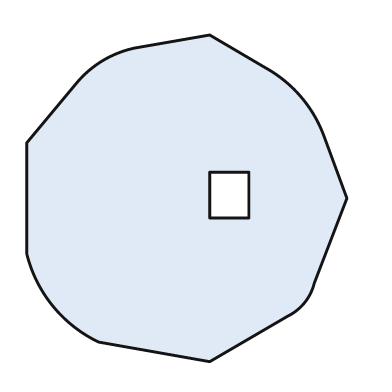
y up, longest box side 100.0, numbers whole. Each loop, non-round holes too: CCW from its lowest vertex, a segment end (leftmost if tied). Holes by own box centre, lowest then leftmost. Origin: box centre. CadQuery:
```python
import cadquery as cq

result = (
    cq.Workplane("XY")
    .moveTo(7.0, -50.0)
    .lineTo(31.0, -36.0)
    .threePointArc((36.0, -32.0), (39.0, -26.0))
    .lineTo(49.0, 0.0)
    .lineTo(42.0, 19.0)
    .threePointArc((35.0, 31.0), (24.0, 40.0))
    .lineTo(7.0, 50.0)
    .lineTo(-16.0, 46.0)
    .threePointArc((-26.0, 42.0), (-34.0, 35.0))
    .lineTo(-49.0, 17.0)
    .lineTo(-49.0, -17.0)
    .threePointArc((-41.0, -33.0), (-27.0, -44.0))
    .close()
    .moveTo(7.0, -6.0)
    .lineTo(19.0, -6.0)
    .lineTo(19.0, 8.0)
    .lineTo(7.0, 8.0)
    .close()
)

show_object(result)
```